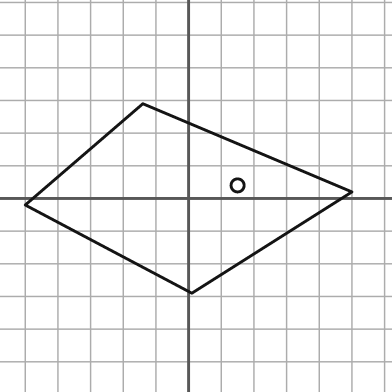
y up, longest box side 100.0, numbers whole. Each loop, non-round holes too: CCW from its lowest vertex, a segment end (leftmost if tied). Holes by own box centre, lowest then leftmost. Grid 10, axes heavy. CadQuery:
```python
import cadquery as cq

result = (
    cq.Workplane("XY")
    .moveTo(1.0, -29.0)
    .lineTo(50.0, 2.0)
    .lineTo(-14.0, 29.0)
    .lineTo(-50.0, -2.0)
    .close()
    .moveTo(15.0, 4.0)
    .circle(2.0)
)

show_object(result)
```